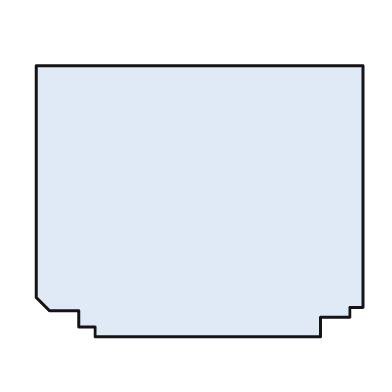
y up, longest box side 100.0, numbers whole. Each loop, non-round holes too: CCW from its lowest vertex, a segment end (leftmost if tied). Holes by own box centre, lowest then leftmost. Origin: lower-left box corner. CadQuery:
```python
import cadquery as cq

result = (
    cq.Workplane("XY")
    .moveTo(18.0, 0.0)
    .lineTo(87.0, 0.0)
    .lineTo(87.0, 6.0)
    .lineTo(96.0, 6.0)
    .lineTo(96.0, 9.0)
    .lineTo(100.0, 9.0)
    .lineTo(100.0, 83.0)
    .lineTo(0.0, 83.0)
    .lineTo(0.0, 12.0)
    .lineTo(4.0, 8.0)
    .lineTo(13.0, 8.0)
    .lineTo(13.0, 3.0)
    .lineTo(18.0, 3.0)
    .close()
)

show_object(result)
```